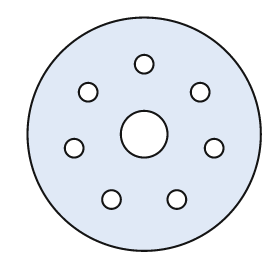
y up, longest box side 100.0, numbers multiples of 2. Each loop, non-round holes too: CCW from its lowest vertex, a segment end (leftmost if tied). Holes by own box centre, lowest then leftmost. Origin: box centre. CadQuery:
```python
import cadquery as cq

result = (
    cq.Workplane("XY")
    .moveTo(0.0, 0.0)
    .circle(50.0)
    .moveTo(-14.0, -28.0)
    .circle(4.0)
    .moveTo(14.0, -28.0)
    .circle(4.0)
    .moveTo(-30.0, -6.0)
    .circle(4.0)
    .moveTo(30.0, -6.0)
    .circle(4.0)
    .moveTo(0.0, 0.0)
    .circle(10.0)
    .moveTo(-24.0, 18.0)
    .circle(4.0)
    .moveTo(24.0, 18.0)
    .circle(4.0)
    .moveTo(0.0, 30.0)
    .circle(4.0)
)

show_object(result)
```